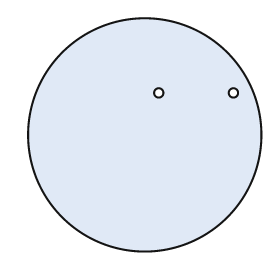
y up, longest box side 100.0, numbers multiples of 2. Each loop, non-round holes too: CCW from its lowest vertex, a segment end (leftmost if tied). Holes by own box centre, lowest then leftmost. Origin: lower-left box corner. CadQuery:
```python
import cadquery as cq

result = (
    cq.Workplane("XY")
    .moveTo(50.0, 50.0)
    .circle(50.0)
    .moveTo(56.0, 68.0)
    .circle(2.0)
    .moveTo(88.0, 68.0)
    .circle(2.0)
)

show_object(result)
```